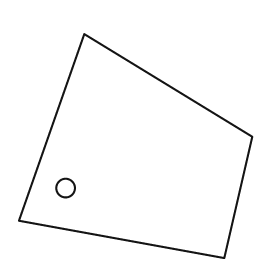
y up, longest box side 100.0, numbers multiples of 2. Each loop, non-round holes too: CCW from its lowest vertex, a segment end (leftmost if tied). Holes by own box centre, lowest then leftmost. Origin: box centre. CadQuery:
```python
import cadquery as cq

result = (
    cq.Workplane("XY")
    .moveTo(38.0, -48.0)
    .lineTo(50.0, 4.0)
    .lineTo(-22.0, 48.0)
    .lineTo(-50.0, -32.0)
    .close()
    .moveTo(-30.0, -18.0)
    .circle(4.0)
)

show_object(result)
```